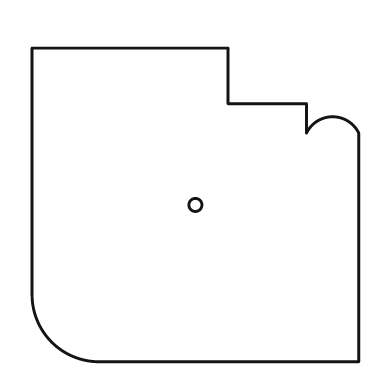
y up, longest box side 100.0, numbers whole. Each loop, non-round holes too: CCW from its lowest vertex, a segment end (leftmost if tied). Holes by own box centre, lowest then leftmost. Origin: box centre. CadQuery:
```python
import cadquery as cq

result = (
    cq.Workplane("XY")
    .moveTo(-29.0, -48.0)
    .lineTo(50.0, -48.0)
    .lineTo(50.0, 22.0)
    .threePointArc((42.0, 27.0), (34.0, 22.0))
    .lineTo(34.0, 31.0)
    .lineTo(10.0, 31.0)
    .lineTo(10.0, 48.0)
    .lineTo(-50.0, 48.0)
    .lineTo(-50.0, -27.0)
    .threePointArc((-44.0, -42.0), (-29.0, -48.0))
    .close()
    .moveTo(0.0, 0.0)
    .circle(2.0)
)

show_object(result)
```